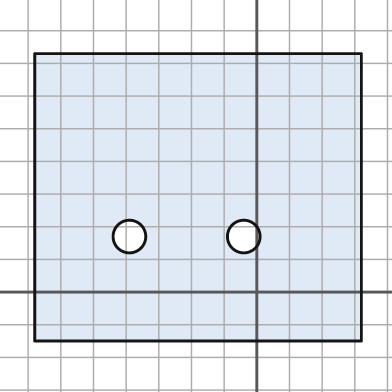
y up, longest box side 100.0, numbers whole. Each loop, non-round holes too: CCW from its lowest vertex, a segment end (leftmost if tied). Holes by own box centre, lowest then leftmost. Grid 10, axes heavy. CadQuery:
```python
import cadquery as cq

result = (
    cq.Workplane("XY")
    .moveTo(-68.0, -15.0)
    .lineTo(32.0, -15.0)
    .lineTo(32.0, 73.0)
    .lineTo(-68.0, 73.0)
    .close()
    .moveTo(-39.0, 17.0)
    .circle(5.0)
    .moveTo(-4.0, 17.0)
    .circle(5.0)
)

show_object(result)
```